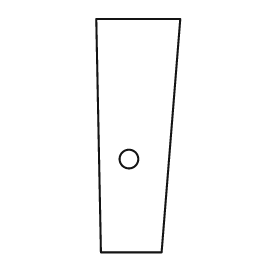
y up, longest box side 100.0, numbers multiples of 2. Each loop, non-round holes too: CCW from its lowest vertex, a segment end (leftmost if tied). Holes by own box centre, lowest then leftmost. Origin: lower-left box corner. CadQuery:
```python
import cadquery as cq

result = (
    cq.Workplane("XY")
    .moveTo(2.0, 0.0)
    .lineTo(28.0, 0.0)
    .lineTo(36.0, 100.0)
    .lineTo(0.0, 100.0)
    .close()
    .moveTo(14.0, 40.0)
    .circle(4.0)
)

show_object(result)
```